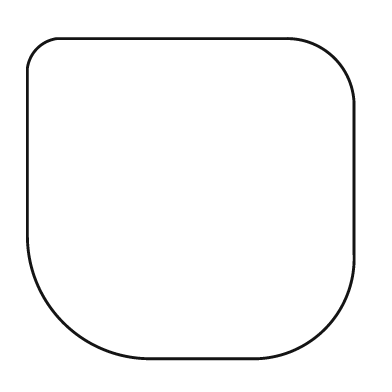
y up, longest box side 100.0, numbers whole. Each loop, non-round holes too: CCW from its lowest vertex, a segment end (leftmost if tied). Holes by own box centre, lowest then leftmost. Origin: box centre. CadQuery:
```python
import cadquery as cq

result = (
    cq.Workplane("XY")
    .moveTo(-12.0, -49.0)
    .lineTo(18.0, -49.0)
    .threePointArc((41.0, -40.0), (50.0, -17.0))
    .lineTo(50.0, 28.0)
    .threePointArc((44.0, 43.0), (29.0, 49.0))
    .lineTo(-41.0, 49.0)
    .threePointArc((-47.0, 46.0), (-50.0, 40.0))
    .lineTo(-50.0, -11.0)
    .threePointArc((-39.0, -38.0), (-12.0, -49.0))
    .close()
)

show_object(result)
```